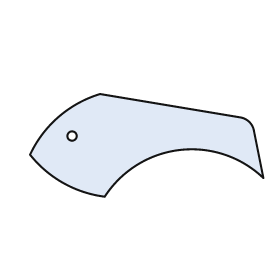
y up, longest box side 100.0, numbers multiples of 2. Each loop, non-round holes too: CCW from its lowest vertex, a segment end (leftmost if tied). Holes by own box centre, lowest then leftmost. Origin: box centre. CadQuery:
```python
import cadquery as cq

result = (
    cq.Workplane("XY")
    .moveTo(-18.0, -22.0)
    .threePointArc((14.0, -2.0), (50.0, -14.0))
    .lineTo(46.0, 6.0)
    .threePointArc((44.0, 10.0), (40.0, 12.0))
    .lineTo(-20.0, 22.0)
    .threePointArc((-38.0, 12.0), (-50.0, -4.0))
    .threePointArc((-36.0, -16.0), (-18.0, -22.0))
    .close()
    .moveTo(-32.0, 4.0)
    .circle(2.0)
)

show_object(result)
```